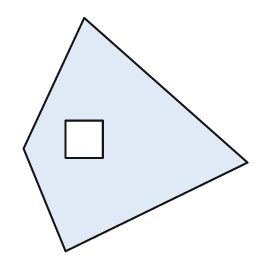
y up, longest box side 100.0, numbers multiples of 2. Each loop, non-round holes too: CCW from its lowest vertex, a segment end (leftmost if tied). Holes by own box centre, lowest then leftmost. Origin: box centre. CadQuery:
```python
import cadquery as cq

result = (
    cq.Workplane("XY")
    .moveTo(-30.0, -50.0)
    .lineTo(48.0, -12.0)
    .lineTo(-22.0, 50.0)
    .lineTo(-48.0, -6.0)
    .close()
    .moveTo(-30.0, -10.0)
    .lineTo(-14.0, -10.0)
    .lineTo(-14.0, 6.0)
    .lineTo(-30.0, 6.0)
    .close()
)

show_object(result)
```